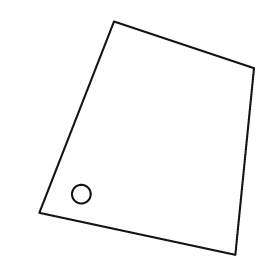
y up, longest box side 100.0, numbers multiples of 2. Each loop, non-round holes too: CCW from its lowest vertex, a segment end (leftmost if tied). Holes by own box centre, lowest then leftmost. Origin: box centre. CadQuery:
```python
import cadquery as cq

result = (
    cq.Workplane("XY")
    .moveTo(38.0, -50.0)
    .lineTo(46.0, 30.0)
    .lineTo(-14.0, 50.0)
    .lineTo(-46.0, -32.0)
    .close()
    .moveTo(-28.0, -24.0)
    .circle(4.0)
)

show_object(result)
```